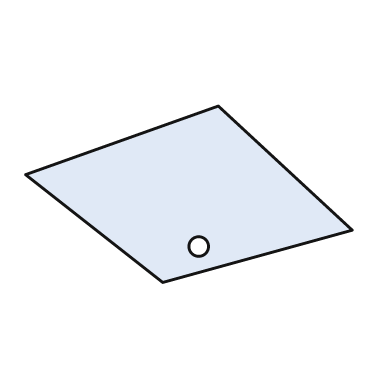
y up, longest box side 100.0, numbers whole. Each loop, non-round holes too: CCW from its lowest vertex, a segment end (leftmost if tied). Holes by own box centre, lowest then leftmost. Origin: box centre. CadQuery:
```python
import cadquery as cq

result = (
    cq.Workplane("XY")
    .moveTo(-8.0, -27.0)
    .lineTo(50.0, -11.0)
    .lineTo(9.0, 27.0)
    .lineTo(-50.0, 6.0)
    .close()
    .moveTo(3.0, -16.0)
    .circle(3.0)
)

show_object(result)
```